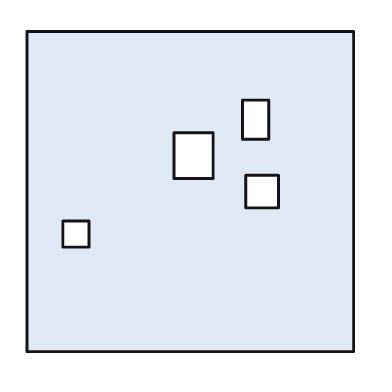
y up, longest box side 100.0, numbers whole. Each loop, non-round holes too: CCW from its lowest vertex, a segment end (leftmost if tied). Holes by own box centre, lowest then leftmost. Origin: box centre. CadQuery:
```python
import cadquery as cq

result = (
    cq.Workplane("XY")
    .moveTo(-50.0, -49.0)
    .lineTo(50.0, -49.0)
    .lineTo(50.0, 49.0)
    .lineTo(-50.0, 49.0)
    .close()
    .moveTo(-39.0, -17.0)
    .lineTo(-31.0, -17.0)
    .lineTo(-31.0, -9.0)
    .lineTo(-39.0, -9.0)
    .close()
    .moveTo(17.0, -5.0)
    .lineTo(27.0, -5.0)
    .lineTo(27.0, 5.0)
    .lineTo(17.0, 5.0)
    .close()
    .moveTo(-5.0, 4.0)
    .lineTo(7.0, 4.0)
    .lineTo(7.0, 18.0)
    .lineTo(-5.0, 18.0)
    .close()
    .moveTo(16.0, 16.0)
    .lineTo(24.0, 16.0)
    .lineTo(24.0, 28.0)
    .lineTo(16.0, 28.0)
    .close()
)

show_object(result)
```